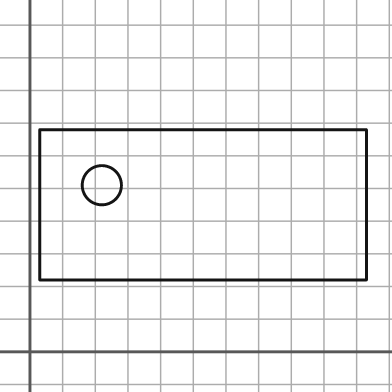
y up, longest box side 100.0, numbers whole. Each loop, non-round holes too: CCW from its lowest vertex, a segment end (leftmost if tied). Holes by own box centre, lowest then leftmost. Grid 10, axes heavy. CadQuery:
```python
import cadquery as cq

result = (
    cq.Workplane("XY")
    .moveTo(3.0, 22.0)
    .lineTo(103.0, 22.0)
    .lineTo(103.0, 68.0)
    .lineTo(3.0, 68.0)
    .close()
    .moveTo(22.0, 51.0)
    .circle(6.0)
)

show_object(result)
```